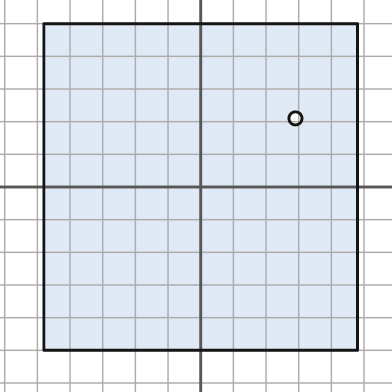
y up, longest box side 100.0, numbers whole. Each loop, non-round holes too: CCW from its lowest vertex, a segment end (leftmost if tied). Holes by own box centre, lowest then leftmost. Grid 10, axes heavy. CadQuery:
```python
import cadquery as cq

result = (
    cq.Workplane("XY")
    .moveTo(-48.0, -50.0)
    .lineTo(48.0, -50.0)
    .lineTo(48.0, 50.0)
    .lineTo(-48.0, 50.0)
    .close()
    .moveTo(29.0, 21.0)
    .circle(2.0)
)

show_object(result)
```